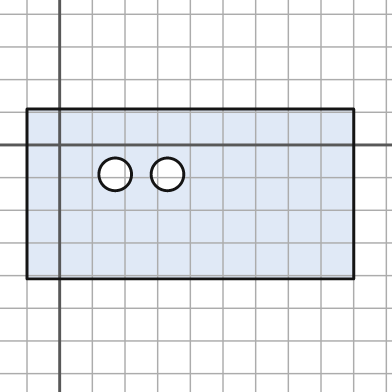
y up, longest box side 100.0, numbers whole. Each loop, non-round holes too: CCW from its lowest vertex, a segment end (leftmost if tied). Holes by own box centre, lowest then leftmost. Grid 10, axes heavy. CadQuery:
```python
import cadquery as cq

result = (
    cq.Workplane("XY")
    .moveTo(-10.0, -41.0)
    .lineTo(90.0, -41.0)
    .lineTo(90.0, 11.0)
    .lineTo(-10.0, 11.0)
    .close()
    .moveTo(17.0, -9.0)
    .circle(5.0)
    .moveTo(33.0, -9.0)
    .circle(5.0)
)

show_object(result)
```